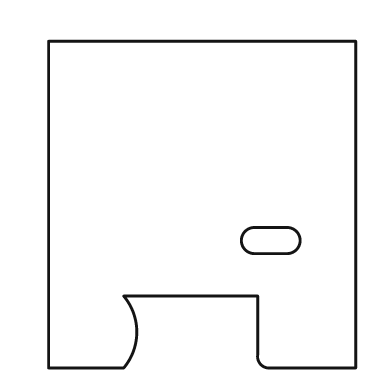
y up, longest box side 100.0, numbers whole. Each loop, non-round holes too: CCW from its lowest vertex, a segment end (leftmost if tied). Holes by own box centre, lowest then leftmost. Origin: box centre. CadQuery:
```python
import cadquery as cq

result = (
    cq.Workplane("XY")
    .moveTo(-47.0, -50.0)
    .lineTo(-24.0, -50.0)
    .threePointArc((-20.0, -39.0), (-24.0, -28.0))
    .lineTo(17.0, -28.0)
    .lineTo(17.0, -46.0)
    .threePointArc((18.0, -49.0), (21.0, -50.0))
    .lineTo(47.0, -50.0)
    .lineTo(47.0, 50.0)
    .lineTo(-47.0, 50.0)
    .close()
    .moveTo(16.0, -15.0)
    .lineTo(26.0, -15.0)
    .threePointArc((30.0, -11.0), (26.0, -7.0))
    .lineTo(16.0, -7.0)
    .threePointArc((12.0, -11.0), (16.0, -15.0))
    .close()
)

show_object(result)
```